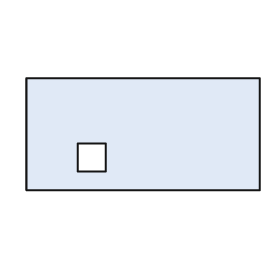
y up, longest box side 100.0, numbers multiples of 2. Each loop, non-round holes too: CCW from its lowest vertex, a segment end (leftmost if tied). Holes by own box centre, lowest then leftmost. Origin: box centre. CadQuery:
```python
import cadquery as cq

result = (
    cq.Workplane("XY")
    .moveTo(-50.0, -24.0)
    .lineTo(50.0, -24.0)
    .lineTo(50.0, 24.0)
    .lineTo(-50.0, 24.0)
    .close()
    .moveTo(-28.0, -16.0)
    .lineTo(-16.0, -16.0)
    .lineTo(-16.0, -4.0)
    .lineTo(-28.0, -4.0)
    .close()
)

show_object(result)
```